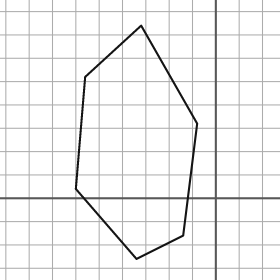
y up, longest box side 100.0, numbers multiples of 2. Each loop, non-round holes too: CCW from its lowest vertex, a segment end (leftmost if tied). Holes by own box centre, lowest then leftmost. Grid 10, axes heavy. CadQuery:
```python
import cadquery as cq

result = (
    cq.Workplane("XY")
    .moveTo(-34.0, -26.0)
    .lineTo(-14.0, -16.0)
    .lineTo(-8.0, 32.0)
    .lineTo(-32.0, 74.0)
    .lineTo(-56.0, 52.0)
    .lineTo(-60.0, 4.0)
    .close()
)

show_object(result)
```